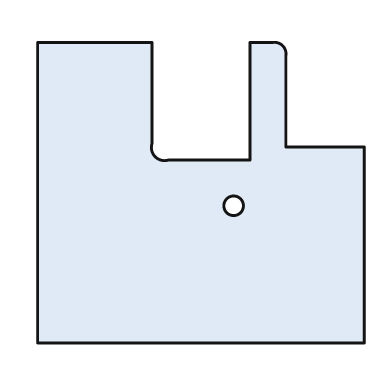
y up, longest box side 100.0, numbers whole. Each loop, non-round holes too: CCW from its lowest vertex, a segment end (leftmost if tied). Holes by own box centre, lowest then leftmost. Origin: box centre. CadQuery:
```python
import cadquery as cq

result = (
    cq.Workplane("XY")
    .moveTo(-50.0, -46.0)
    .lineTo(50.0, -46.0)
    .lineTo(50.0, 14.0)
    .lineTo(26.0, 14.0)
    .lineTo(26.0, 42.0)
    .threePointArc((25.0, 45.0), (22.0, 46.0))
    .lineTo(15.0, 46.0)
    .lineTo(15.0, 10.0)
    .lineTo(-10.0, 10.0)
    .threePointArc((-14.0, 11.0), (-15.0, 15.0))
    .lineTo(-15.0, 46.0)
    .lineTo(-50.0, 46.0)
    .close()
    .moveTo(10.0, -4.0)
    .circle(3.0)
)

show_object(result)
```